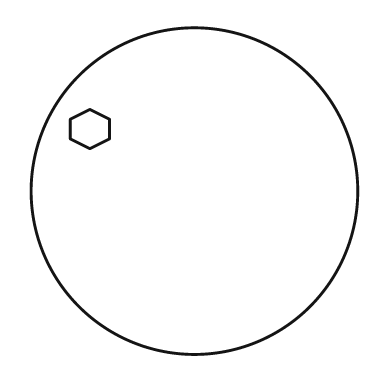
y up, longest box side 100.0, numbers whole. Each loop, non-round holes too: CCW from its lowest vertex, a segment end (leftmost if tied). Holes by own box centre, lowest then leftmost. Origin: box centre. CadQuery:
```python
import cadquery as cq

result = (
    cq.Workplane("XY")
    .moveTo(0.0, 0.0)
    .circle(50.0)
    .moveTo(-32.0, 13.0)
    .lineTo(-26.0, 16.0)
    .lineTo(-26.0, 22.0)
    .lineTo(-32.0, 25.0)
    .lineTo(-38.0, 22.0)
    .lineTo(-38.0, 16.0)
    .close()
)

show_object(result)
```